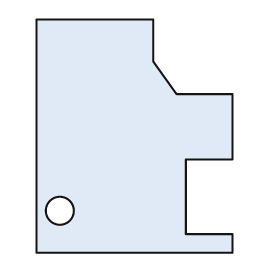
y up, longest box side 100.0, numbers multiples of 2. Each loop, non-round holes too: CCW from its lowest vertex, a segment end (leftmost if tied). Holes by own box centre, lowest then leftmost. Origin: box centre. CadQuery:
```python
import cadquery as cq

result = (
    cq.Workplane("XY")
    .moveTo(-42.0, -50.0)
    .lineTo(42.0, -50.0)
    .lineTo(42.0, -42.0)
    .lineTo(22.0, -42.0)
    .lineTo(22.0, -10.0)
    .lineTo(42.0, -10.0)
    .lineTo(42.0, 18.0)
    .lineTo(18.0, 18.0)
    .lineTo(8.0, 32.0)
    .lineTo(8.0, 50.0)
    .lineTo(-42.0, 50.0)
    .close()
    .moveTo(-32.0, -32.0)
    .circle(6.0)
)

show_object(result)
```